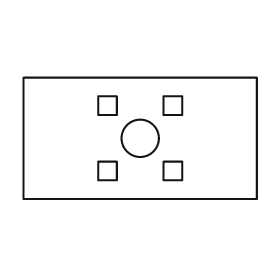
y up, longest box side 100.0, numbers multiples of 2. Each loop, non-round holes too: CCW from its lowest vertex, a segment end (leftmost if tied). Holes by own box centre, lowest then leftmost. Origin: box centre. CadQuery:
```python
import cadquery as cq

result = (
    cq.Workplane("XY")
    .moveTo(-50.0, -26.0)
    .lineTo(50.0, -26.0)
    .lineTo(50.0, 26.0)
    .lineTo(-50.0, 26.0)
    .close()
    .moveTo(-18.0, -18.0)
    .lineTo(-10.0, -18.0)
    .lineTo(-10.0, -10.0)
    .lineTo(-18.0, -10.0)
    .close()
    .moveTo(10.0, -18.0)
    .lineTo(18.0, -18.0)
    .lineTo(18.0, -10.0)
    .lineTo(10.0, -10.0)
    .close()
    .moveTo(0.0, 0.0)
    .circle(8.0)
    .moveTo(-18.0, 10.0)
    .lineTo(-10.0, 10.0)
    .lineTo(-10.0, 18.0)
    .lineTo(-18.0, 18.0)
    .close()
    .moveTo(10.0, 10.0)
    .lineTo(18.0, 10.0)
    .lineTo(18.0, 18.0)
    .lineTo(10.0, 18.0)
    .close()
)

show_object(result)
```